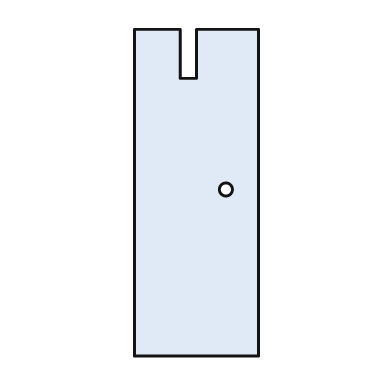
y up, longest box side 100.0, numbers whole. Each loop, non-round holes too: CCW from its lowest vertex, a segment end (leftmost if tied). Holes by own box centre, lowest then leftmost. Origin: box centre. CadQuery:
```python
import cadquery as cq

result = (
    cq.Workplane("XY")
    .moveTo(-19.0, -50.0)
    .lineTo(19.0, -50.0)
    .lineTo(19.0, 50.0)
    .lineTo(0.0, 50.0)
    .lineTo(0.0, 35.0)
    .lineTo(-5.0, 35.0)
    .lineTo(-5.0, 50.0)
    .lineTo(-19.0, 50.0)
    .close()
    .moveTo(9.0, 1.0)
    .circle(2.0)
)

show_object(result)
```